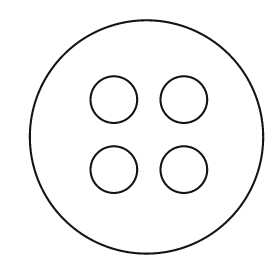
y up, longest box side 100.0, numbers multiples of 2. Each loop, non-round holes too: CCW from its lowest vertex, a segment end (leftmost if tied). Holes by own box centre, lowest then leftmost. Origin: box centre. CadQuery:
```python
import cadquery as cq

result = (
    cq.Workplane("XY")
    .moveTo(0.0, 0.0)
    .circle(50.0)
    .moveTo(-14.0, -14.0)
    .circle(10.0)
    .moveTo(16.0, -14.0)
    .circle(10.0)
    .moveTo(-14.0, 16.0)
    .circle(10.0)
    .moveTo(16.0, 16.0)
    .circle(10.0)
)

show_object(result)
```